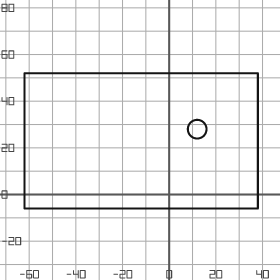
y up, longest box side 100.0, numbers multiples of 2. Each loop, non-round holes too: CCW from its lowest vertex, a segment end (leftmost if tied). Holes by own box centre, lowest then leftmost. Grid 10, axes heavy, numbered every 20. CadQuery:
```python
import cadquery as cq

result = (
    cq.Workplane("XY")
    .moveTo(-62.0, -6.0)
    .lineTo(38.0, -6.0)
    .lineTo(38.0, 52.0)
    .lineTo(-62.0, 52.0)
    .close()
    .moveTo(12.0, 28.0)
    .circle(4.0)
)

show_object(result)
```